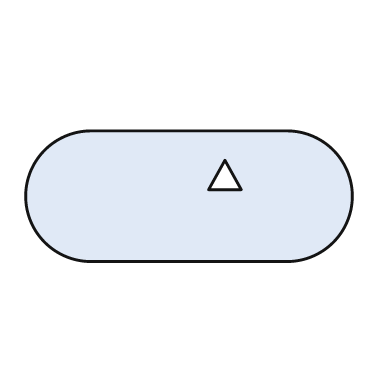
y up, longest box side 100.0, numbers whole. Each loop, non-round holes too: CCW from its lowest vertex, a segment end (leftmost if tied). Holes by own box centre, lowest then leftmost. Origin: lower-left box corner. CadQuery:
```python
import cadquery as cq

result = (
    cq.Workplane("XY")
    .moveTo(20.0, 0.0)
    .lineTo(80.0, 0.0)
    .threePointArc((100.0, 20.0), (80.0, 40.0))
    .lineTo(20.0, 40.0)
    .threePointArc((0.0, 20.0), (20.0, 0.0))
    .close()
    .moveTo(56.0, 22.0)
    .lineTo(66.0, 22.0)
    .lineTo(61.0, 31.0)
    .close()
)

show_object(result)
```